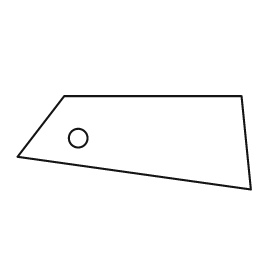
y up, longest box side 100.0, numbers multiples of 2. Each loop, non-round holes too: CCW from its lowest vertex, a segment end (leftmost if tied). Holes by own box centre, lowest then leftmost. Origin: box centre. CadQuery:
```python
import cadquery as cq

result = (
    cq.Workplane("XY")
    .moveTo(50.0, -20.0)
    .lineTo(46.0, 20.0)
    .lineTo(-30.0, 20.0)
    .lineTo(-50.0, -6.0)
    .close()
    .moveTo(-24.0, 2.0)
    .circle(4.0)
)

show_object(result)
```